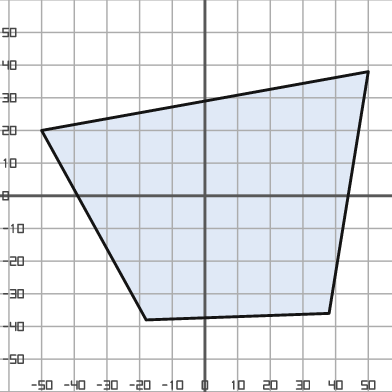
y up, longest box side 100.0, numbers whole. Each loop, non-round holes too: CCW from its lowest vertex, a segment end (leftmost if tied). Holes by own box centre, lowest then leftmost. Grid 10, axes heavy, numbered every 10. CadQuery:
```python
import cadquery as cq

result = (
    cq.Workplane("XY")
    .moveTo(-18.0, -38.0)
    .lineTo(38.0, -36.0)
    .lineTo(50.0, 38.0)
    .lineTo(-50.0, 20.0)
    .close()
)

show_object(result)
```